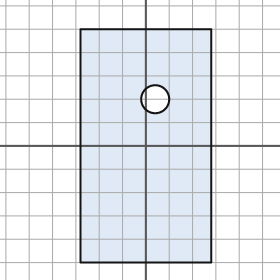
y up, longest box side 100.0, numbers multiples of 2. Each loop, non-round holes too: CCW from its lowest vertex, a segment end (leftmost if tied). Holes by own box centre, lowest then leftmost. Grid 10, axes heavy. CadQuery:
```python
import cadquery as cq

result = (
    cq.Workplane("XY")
    .moveTo(-28.0, -50.0)
    .lineTo(28.0, -50.0)
    .lineTo(28.0, 50.0)
    .lineTo(-28.0, 50.0)
    .close()
    .moveTo(4.0, 20.0)
    .circle(6.0)
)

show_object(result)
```